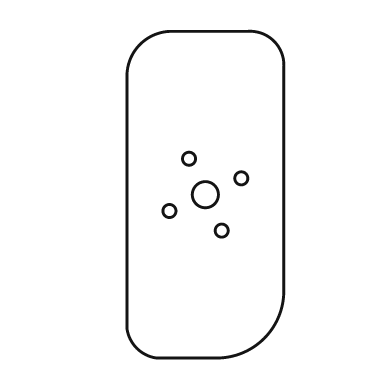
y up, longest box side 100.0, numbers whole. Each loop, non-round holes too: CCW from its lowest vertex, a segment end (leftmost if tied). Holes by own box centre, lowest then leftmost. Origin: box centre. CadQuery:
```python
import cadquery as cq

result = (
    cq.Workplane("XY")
    .moveTo(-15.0, -50.0)
    .lineTo(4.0, -50.0)
    .threePointArc((18.0, -44.0), (24.0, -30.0))
    .lineTo(24.0, 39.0)
    .threePointArc((21.0, 47.0), (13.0, 50.0))
    .lineTo(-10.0, 50.0)
    .threePointArc((-20.0, 46.0), (-24.0, 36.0))
    .lineTo(-24.0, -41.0)
    .threePointArc((-21.0, -47.0), (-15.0, -50.0))
    .close()
    .moveTo(5.0, -11.0)
    .circle(2.0)
    .moveTo(-11.0, -5.0)
    .circle(2.0)
    .moveTo(0.0, 0.0)
    .circle(4.0)
    .moveTo(11.0, 5.0)
    .circle(2.0)
    .moveTo(-5.0, 11.0)
    .circle(2.0)
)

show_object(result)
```